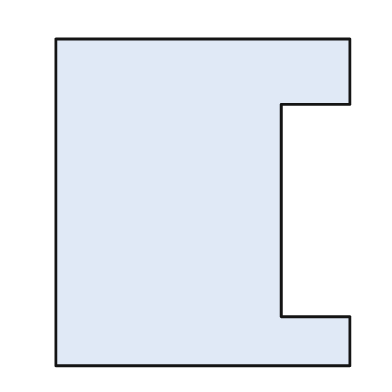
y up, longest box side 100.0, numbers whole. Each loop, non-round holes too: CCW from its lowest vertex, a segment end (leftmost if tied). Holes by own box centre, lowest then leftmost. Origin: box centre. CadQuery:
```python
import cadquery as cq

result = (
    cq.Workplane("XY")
    .moveTo(-45.0, -50.0)
    .lineTo(45.0, -50.0)
    .lineTo(45.0, -35.0)
    .lineTo(24.0, -35.0)
    .lineTo(24.0, 30.0)
    .lineTo(45.0, 30.0)
    .lineTo(45.0, 50.0)
    .lineTo(-45.0, 50.0)
    .close()
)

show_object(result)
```